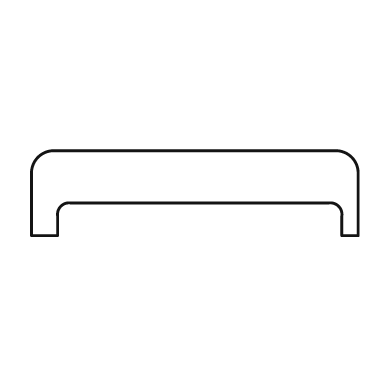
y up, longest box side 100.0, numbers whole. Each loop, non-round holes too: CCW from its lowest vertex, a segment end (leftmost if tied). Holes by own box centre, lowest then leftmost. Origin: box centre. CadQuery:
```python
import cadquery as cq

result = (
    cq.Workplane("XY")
    .moveTo(-50.0, -13.0)
    .lineTo(-42.0, -13.0)
    .lineTo(-42.0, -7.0)
    .threePointArc((-41.0, -4.0), (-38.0, -3.0))
    .lineTo(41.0, -3.0)
    .threePointArc((44.0, -4.0), (45.0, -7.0))
    .lineTo(45.0, -13.0)
    .lineTo(50.0, -13.0)
    .lineTo(50.0, 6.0)
    .threePointArc((48.0, 11.0), (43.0, 13.0))
    .lineTo(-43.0, 13.0)
    .threePointArc((-48.0, 11.0), (-50.0, 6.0))
    .close()
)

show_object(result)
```